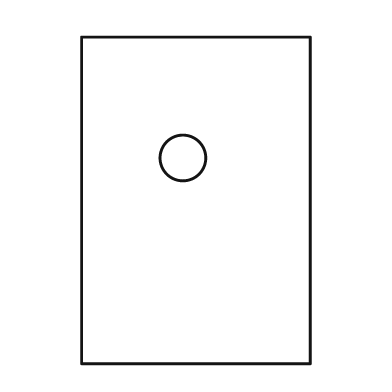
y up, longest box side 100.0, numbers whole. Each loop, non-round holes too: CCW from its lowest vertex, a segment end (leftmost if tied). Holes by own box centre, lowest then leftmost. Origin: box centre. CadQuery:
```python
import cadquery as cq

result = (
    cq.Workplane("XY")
    .moveTo(-35.0, -50.0)
    .lineTo(35.0, -50.0)
    .lineTo(35.0, 50.0)
    .lineTo(-35.0, 50.0)
    .close()
    .moveTo(-4.0, 13.0)
    .circle(7.0)
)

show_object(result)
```